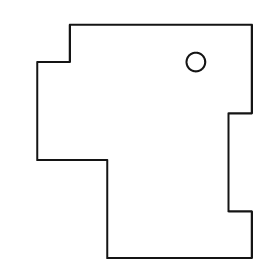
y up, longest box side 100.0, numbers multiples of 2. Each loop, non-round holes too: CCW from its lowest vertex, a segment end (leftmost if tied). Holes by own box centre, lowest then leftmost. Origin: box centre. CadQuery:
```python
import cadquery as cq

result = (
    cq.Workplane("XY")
    .moveTo(-16.0, -50.0)
    .lineTo(46.0, -50.0)
    .lineTo(46.0, -30.0)
    .lineTo(36.0, -30.0)
    .lineTo(36.0, 12.0)
    .lineTo(46.0, 12.0)
    .lineTo(46.0, 50.0)
    .lineTo(-32.0, 50.0)
    .lineTo(-32.0, 34.0)
    .lineTo(-46.0, 34.0)
    .lineTo(-46.0, -8.0)
    .lineTo(-16.0, -8.0)
    .close()
    .moveTo(22.0, 34.0)
    .circle(4.0)
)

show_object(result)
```